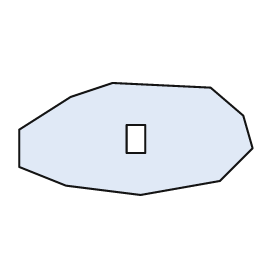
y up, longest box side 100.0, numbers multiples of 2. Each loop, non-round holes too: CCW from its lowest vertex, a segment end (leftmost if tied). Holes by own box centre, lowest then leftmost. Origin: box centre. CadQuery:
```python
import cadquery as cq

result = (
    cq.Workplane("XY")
    .moveTo(2.0, -24.0)
    .lineTo(36.0, -18.0)
    .lineTo(50.0, -4.0)
    .lineTo(46.0, 10.0)
    .lineTo(32.0, 22.0)
    .lineTo(-10.0, 24.0)
    .lineTo(-28.0, 18.0)
    .lineTo(-50.0, 4.0)
    .lineTo(-50.0, -12.0)
    .lineTo(-30.0, -20.0)
    .close()
    .moveTo(-4.0, -6.0)
    .lineTo(4.0, -6.0)
    .lineTo(4.0, 6.0)
    .lineTo(-4.0, 6.0)
    .close()
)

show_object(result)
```